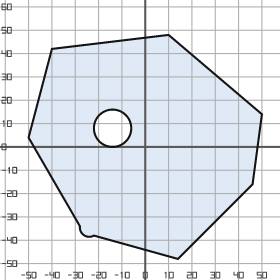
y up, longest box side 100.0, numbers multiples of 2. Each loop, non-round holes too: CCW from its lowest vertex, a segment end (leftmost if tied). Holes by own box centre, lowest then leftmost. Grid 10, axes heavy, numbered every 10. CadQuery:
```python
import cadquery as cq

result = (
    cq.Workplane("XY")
    .moveTo(14.0, -48.0)
    .lineTo(46.0, -16.0)
    .lineTo(50.0, 14.0)
    .lineTo(10.0, 48.0)
    .lineTo(-40.0, 42.0)
    .lineTo(-50.0, 4.0)
    .lineTo(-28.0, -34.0)
    .threePointArc((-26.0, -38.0), (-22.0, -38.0))
    .close()
    .moveTo(-14.0, 8.0)
    .circle(8.0)
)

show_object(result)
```